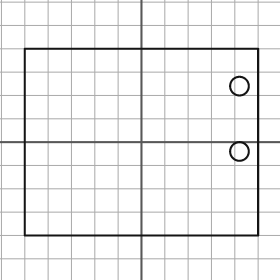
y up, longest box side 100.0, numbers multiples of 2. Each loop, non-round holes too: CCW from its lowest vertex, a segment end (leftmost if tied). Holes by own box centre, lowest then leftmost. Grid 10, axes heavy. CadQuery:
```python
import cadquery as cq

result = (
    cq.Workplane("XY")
    .moveTo(-50.0, -40.0)
    .lineTo(50.0, -40.0)
    .lineTo(50.0, 40.0)
    .lineTo(-50.0, 40.0)
    .close()
    .moveTo(42.0, -4.0)
    .circle(4.0)
    .moveTo(42.0, 24.0)
    .circle(4.0)
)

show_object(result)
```